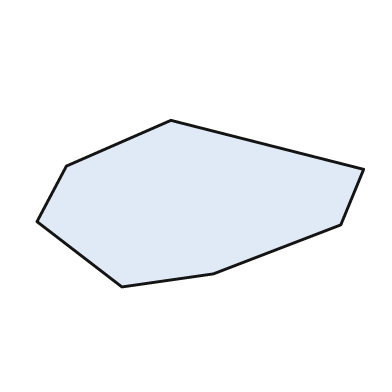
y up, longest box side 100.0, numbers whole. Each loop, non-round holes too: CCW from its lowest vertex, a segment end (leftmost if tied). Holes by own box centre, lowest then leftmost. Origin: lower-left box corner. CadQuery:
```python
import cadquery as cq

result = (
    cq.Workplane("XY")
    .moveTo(26.0, 0.0)
    .lineTo(54.0, 4.0)
    .lineTo(93.0, 19.0)
    .lineTo(100.0, 36.0)
    .lineTo(41.0, 51.0)
    .lineTo(9.0, 37.0)
    .lineTo(0.0, 20.0)
    .close()
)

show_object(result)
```